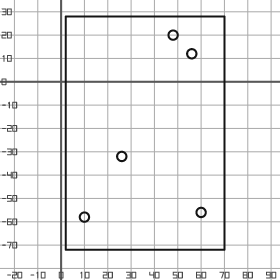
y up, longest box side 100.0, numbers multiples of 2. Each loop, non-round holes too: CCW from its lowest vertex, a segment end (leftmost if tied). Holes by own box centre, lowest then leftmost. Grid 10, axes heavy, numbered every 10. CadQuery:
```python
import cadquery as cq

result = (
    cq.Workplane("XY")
    .moveTo(2.0, -72.0)
    .lineTo(70.0, -72.0)
    .lineTo(70.0, 28.0)
    .lineTo(2.0, 28.0)
    .close()
    .moveTo(10.0, -58.0)
    .circle(2.0)
    .moveTo(60.0, -56.0)
    .circle(2.0)
    .moveTo(26.0, -32.0)
    .circle(2.0)
    .moveTo(56.0, 12.0)
    .circle(2.0)
    .moveTo(48.0, 20.0)
    .circle(2.0)
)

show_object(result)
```